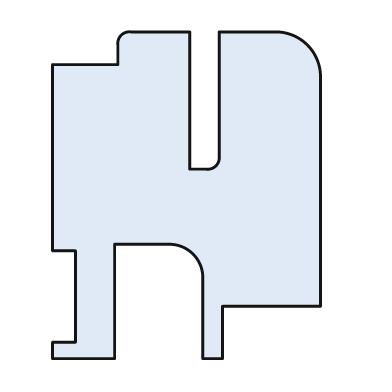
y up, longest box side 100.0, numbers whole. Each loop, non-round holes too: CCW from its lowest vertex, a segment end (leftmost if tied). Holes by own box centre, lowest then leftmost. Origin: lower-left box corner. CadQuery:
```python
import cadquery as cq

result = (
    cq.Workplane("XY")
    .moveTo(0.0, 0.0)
    .lineTo(19.0, 0.0)
    .lineTo(19.0, 35.0)
    .lineTo(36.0, 35.0)
    .threePointArc((43.0, 32.0), (46.0, 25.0))
    .lineTo(46.0, 0.0)
    .lineTo(52.0, 0.0)
    .lineTo(52.0, 16.0)
    .lineTo(82.0, 16.0)
    .lineTo(82.0, 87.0)
    .threePointArc((78.0, 96.0), (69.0, 100.0))
    .lineTo(51.0, 100.0)
    .lineTo(51.0, 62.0)
    .threePointArc((50.0, 59.0), (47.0, 58.0))
    .lineTo(42.0, 58.0)
    .lineTo(42.0, 100.0)
    .lineTo(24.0, 100.0)
    .threePointArc((21.0, 99.0), (20.0, 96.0))
    .lineTo(20.0, 90.0)
    .lineTo(0.0, 90.0)
    .lineTo(0.0, 33.0)
    .lineTo(7.0, 33.0)
    .lineTo(7.0, 5.0)
    .lineTo(0.0, 5.0)
    .close()
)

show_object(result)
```